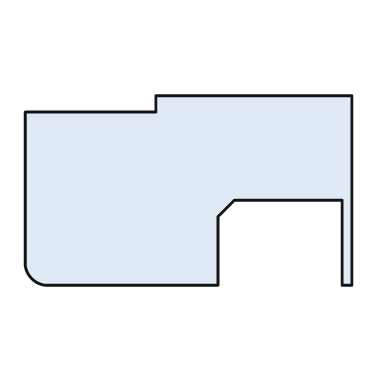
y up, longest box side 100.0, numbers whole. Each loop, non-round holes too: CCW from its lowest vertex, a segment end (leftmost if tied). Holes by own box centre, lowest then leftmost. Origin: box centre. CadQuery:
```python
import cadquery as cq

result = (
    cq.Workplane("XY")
    .moveTo(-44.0, -29.0)
    .lineTo(9.0, -29.0)
    .lineTo(9.0, -8.0)
    .lineTo(14.0, -3.0)
    .lineTo(47.0, -3.0)
    .lineTo(47.0, -29.0)
    .lineTo(50.0, -29.0)
    .lineTo(50.0, 29.0)
    .lineTo(-10.0, 29.0)
    .lineTo(-10.0, 24.0)
    .lineTo(-50.0, 24.0)
    .lineTo(-50.0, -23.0)
    .threePointArc((-48.0, -27.0), (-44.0, -29.0))
    .close()
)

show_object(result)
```